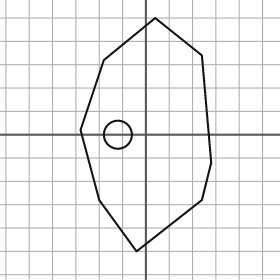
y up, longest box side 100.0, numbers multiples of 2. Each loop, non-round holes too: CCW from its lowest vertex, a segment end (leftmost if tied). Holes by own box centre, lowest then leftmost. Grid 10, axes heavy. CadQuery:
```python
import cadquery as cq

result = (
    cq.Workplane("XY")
    .moveTo(-4.0, -50.0)
    .lineTo(24.0, -28.0)
    .lineTo(28.0, -12.0)
    .lineTo(24.0, 34.0)
    .lineTo(4.0, 50.0)
    .lineTo(-18.0, 32.0)
    .lineTo(-28.0, 2.0)
    .lineTo(-20.0, -28.0)
    .close()
    .moveTo(-12.0, 0.0)
    .circle(6.0)
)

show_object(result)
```